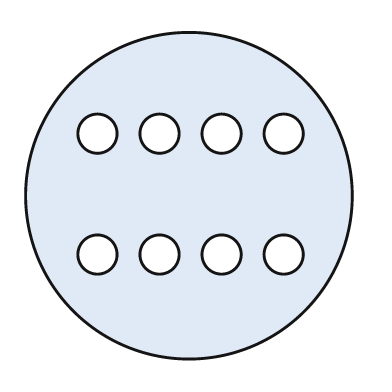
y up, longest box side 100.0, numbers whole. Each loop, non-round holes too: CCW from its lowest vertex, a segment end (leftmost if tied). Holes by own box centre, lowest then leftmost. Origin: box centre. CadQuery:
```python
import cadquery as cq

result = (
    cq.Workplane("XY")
    .moveTo(0.0, 0.0)
    .circle(50.0)
    .moveTo(-28.0, -18.0)
    .circle(6.0)
    .moveTo(-9.0, -18.0)
    .circle(6.0)
    .moveTo(10.0, -18.0)
    .circle(6.0)
    .moveTo(29.0, -18.0)
    .circle(6.0)
    .moveTo(-28.0, 19.0)
    .circle(6.0)
    .moveTo(-9.0, 19.0)
    .circle(6.0)
    .moveTo(10.0, 19.0)
    .circle(6.0)
    .moveTo(29.0, 19.0)
    .circle(6.0)
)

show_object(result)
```